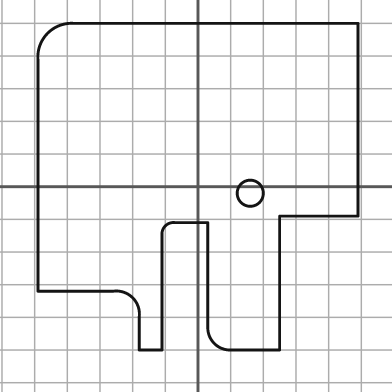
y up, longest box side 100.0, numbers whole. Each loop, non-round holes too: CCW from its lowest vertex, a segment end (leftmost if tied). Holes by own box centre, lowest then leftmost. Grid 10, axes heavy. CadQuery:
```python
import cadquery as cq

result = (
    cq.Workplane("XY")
    .moveTo(-18.0, -50.0)
    .lineTo(-11.0, -50.0)
    .lineTo(-11.0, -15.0)
    .threePointArc((-10.0, -12.0), (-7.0, -11.0))
    .lineTo(3.0, -11.0)
    .lineTo(3.0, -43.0)
    .threePointArc((5.0, -48.0), (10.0, -50.0))
    .lineTo(25.0, -50.0)
    .lineTo(25.0, -9.0)
    .lineTo(49.0, -9.0)
    .lineTo(49.0, 50.0)
    .lineTo(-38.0, 50.0)
    .threePointArc((-46.0, 47.0), (-49.0, 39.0))
    .lineTo(-49.0, -32.0)
    .lineTo(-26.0, -32.0)
    .threePointArc((-20.0, -34.0), (-18.0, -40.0))
    .close()
    .moveTo(16.0, -2.0)
    .circle(4.0)
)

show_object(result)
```